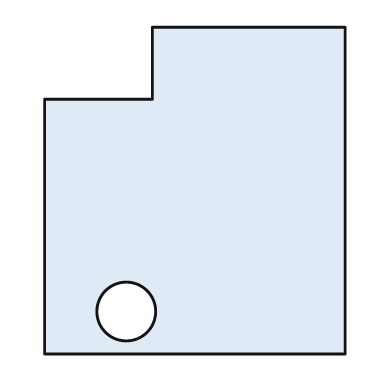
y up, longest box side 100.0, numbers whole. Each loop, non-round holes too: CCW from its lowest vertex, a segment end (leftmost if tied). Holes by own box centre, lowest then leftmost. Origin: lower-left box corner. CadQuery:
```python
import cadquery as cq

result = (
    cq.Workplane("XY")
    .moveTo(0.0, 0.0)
    .lineTo(92.0, 0.0)
    .lineTo(92.0, 100.0)
    .lineTo(33.0, 100.0)
    .lineTo(33.0, 78.0)
    .lineTo(0.0, 78.0)
    .close()
    .moveTo(25.0, 13.0)
    .circle(9.0)
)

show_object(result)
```